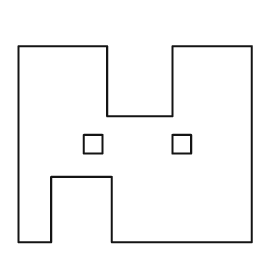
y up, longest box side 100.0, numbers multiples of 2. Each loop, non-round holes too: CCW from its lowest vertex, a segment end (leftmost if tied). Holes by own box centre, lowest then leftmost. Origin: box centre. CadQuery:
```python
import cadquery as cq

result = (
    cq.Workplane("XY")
    .moveTo(-50.0, -42.0)
    .lineTo(-36.0, -42.0)
    .lineTo(-36.0, -14.0)
    .lineTo(-10.0, -14.0)
    .lineTo(-10.0, -42.0)
    .lineTo(50.0, -42.0)
    .lineTo(50.0, 42.0)
    .lineTo(16.0, 42.0)
    .lineTo(16.0, 12.0)
    .lineTo(-12.0, 12.0)
    .lineTo(-12.0, 42.0)
    .lineTo(-50.0, 42.0)
    .close()
    .moveTo(-22.0, -4.0)
    .lineTo(-14.0, -4.0)
    .lineTo(-14.0, 4.0)
    .lineTo(-22.0, 4.0)
    .close()
    .moveTo(16.0, -4.0)
    .lineTo(24.0, -4.0)
    .lineTo(24.0, 4.0)
    .lineTo(16.0, 4.0)
    .close()
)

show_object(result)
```